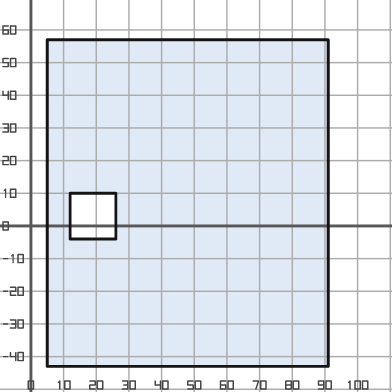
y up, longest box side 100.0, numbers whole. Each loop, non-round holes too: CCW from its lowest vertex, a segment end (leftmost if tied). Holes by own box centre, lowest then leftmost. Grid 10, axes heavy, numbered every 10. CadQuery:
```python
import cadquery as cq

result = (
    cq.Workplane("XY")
    .moveTo(5.0, -43.0)
    .lineTo(91.0, -43.0)
    .lineTo(91.0, 57.0)
    .lineTo(5.0, 57.0)
    .close()
    .moveTo(12.0, -4.0)
    .lineTo(26.0, -4.0)
    .lineTo(26.0, 10.0)
    .lineTo(12.0, 10.0)
    .close()
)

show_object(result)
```